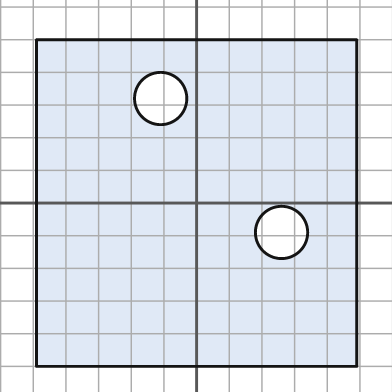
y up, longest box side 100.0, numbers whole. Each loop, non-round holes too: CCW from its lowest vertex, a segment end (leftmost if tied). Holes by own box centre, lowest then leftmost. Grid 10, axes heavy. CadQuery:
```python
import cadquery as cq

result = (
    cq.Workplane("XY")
    .moveTo(-49.0, -50.0)
    .lineTo(49.0, -50.0)
    .lineTo(49.0, 50.0)
    .lineTo(-49.0, 50.0)
    .close()
    .moveTo(26.0, -9.0)
    .circle(8.0)
    .moveTo(-11.0, 32.0)
    .circle(8.0)
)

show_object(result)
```